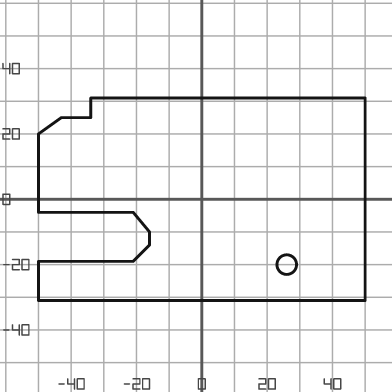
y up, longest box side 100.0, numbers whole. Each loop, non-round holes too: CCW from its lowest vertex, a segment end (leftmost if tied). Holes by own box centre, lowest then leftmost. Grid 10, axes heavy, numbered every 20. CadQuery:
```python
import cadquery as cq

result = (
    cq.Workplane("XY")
    .moveTo(-50.0, -31.0)
    .lineTo(50.0, -31.0)
    .lineTo(50.0, 31.0)
    .lineTo(-34.0, 31.0)
    .lineTo(-34.0, 25.0)
    .lineTo(-43.0, 25.0)
    .lineTo(-50.0, 20.0)
    .lineTo(-50.0, -4.0)
    .lineTo(-21.0, -4.0)
    .lineTo(-16.0, -10.0)
    .lineTo(-16.0, -14.0)
    .lineTo(-21.0, -19.0)
    .lineTo(-50.0, -19.0)
    .close()
    .moveTo(26.0, -20.0)
    .circle(3.0)
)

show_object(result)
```